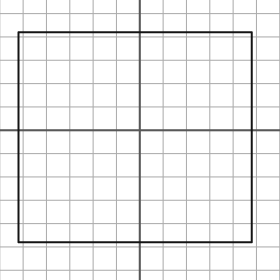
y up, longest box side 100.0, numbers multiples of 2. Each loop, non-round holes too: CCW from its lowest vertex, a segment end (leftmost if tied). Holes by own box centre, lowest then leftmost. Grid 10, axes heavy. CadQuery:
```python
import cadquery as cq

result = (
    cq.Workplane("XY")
    .moveTo(-52.0, -48.0)
    .lineTo(48.0, -48.0)
    .lineTo(48.0, 42.0)
    .lineTo(-52.0, 42.0)
    .close()
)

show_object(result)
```